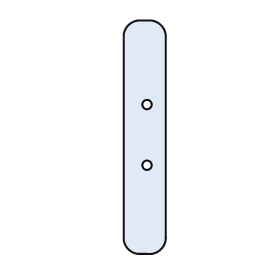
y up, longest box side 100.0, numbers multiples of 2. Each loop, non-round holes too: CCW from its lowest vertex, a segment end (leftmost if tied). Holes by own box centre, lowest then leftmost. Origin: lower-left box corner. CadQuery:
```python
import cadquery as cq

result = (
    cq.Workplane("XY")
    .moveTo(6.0, 0.0)
    .lineTo(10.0, 0.0)
    .threePointArc((16.0, 2.0), (18.0, 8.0))
    .lineTo(18.0, 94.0)
    .threePointArc((16.0, 98.0), (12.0, 100.0))
    .lineTo(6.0, 100.0)
    .threePointArc((2.0, 98.0), (0.0, 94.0))
    .lineTo(0.0, 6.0)
    .threePointArc((2.0, 2.0), (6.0, 0.0))
    .close()
    .moveTo(10.0, 38.0)
    .circle(2.0)
    .moveTo(10.0, 64.0)
    .circle(2.0)
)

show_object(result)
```